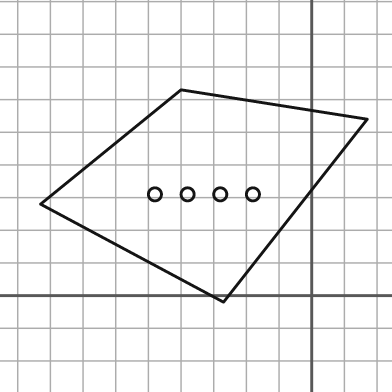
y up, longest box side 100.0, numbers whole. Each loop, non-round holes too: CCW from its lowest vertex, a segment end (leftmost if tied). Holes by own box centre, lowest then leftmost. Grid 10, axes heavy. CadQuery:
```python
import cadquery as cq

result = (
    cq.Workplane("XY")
    .moveTo(-27.0, -2.0)
    .lineTo(17.0, 54.0)
    .lineTo(-40.0, 63.0)
    .lineTo(-83.0, 28.0)
    .close()
    .moveTo(-48.0, 31.0)
    .circle(2.0)
    .moveTo(-38.0, 31.0)
    .circle(2.0)
    .moveTo(-28.0, 31.0)
    .circle(2.0)
    .moveTo(-18.0, 31.0)
    .circle(2.0)
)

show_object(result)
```